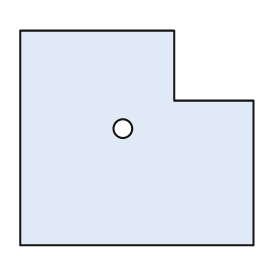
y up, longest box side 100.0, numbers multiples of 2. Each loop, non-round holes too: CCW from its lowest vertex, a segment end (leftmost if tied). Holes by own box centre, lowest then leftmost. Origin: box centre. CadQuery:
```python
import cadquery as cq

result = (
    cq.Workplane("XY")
    .moveTo(-50.0, -46.0)
    .lineTo(50.0, -46.0)
    .lineTo(50.0, 16.0)
    .lineTo(16.0, 16.0)
    .lineTo(16.0, 46.0)
    .lineTo(-50.0, 46.0)
    .close()
    .moveTo(-6.0, 4.0)
    .circle(4.0)
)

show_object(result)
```